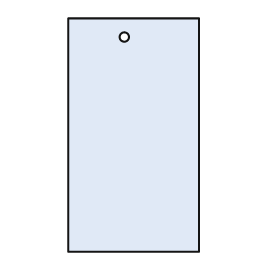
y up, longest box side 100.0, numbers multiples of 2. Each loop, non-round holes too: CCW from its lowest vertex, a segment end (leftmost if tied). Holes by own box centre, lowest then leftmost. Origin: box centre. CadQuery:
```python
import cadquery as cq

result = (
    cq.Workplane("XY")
    .moveTo(-28.0, -50.0)
    .lineTo(28.0, -50.0)
    .lineTo(28.0, 50.0)
    .lineTo(-28.0, 50.0)
    .close()
    .moveTo(-4.0, 42.0)
    .circle(2.0)
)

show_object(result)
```